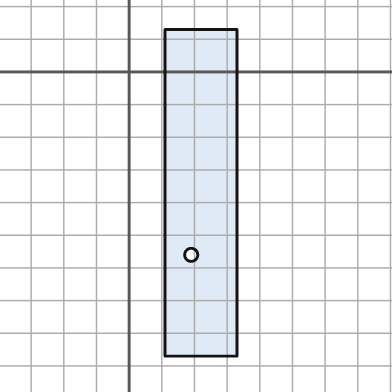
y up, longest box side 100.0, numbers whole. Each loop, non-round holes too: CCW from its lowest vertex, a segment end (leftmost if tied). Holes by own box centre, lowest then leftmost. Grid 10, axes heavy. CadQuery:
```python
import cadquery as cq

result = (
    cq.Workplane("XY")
    .moveTo(11.0, -87.0)
    .lineTo(33.0, -87.0)
    .lineTo(33.0, 13.0)
    .lineTo(11.0, 13.0)
    .close()
    .moveTo(19.0, -56.0)
    .circle(2.0)
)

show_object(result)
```